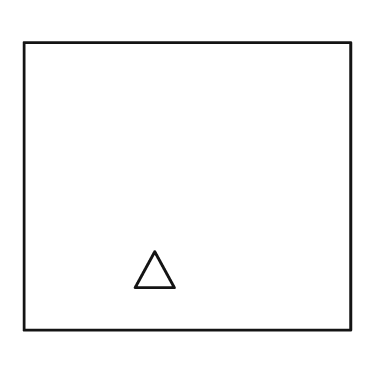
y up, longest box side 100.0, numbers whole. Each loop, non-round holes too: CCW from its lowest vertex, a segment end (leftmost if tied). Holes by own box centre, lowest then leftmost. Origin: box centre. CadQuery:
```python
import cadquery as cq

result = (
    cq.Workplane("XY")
    .moveTo(-50.0, -44.0)
    .lineTo(50.0, -44.0)
    .lineTo(50.0, 44.0)
    .lineTo(-50.0, 44.0)
    .close()
    .moveTo(-16.0, -31.0)
    .lineTo(-4.0, -31.0)
    .lineTo(-10.0, -20.0)
    .close()
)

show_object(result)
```